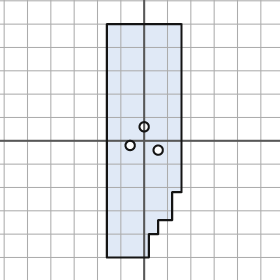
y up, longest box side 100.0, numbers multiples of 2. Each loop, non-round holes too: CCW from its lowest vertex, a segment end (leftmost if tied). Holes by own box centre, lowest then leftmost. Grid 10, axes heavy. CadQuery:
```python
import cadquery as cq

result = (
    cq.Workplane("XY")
    .moveTo(-16.0, -50.0)
    .lineTo(2.0, -50.0)
    .lineTo(2.0, -40.0)
    .lineTo(6.0, -40.0)
    .lineTo(6.0, -34.0)
    .lineTo(12.0, -34.0)
    .lineTo(12.0, -22.0)
    .lineTo(16.0, -22.0)
    .lineTo(16.0, 50.0)
    .lineTo(-16.0, 50.0)
    .close()
    .moveTo(6.0, -4.0)
    .circle(2.0)
    .moveTo(-6.0, -2.0)
    .circle(2.0)
    .moveTo(0.0, 6.0)
    .circle(2.0)
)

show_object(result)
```